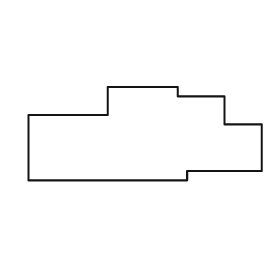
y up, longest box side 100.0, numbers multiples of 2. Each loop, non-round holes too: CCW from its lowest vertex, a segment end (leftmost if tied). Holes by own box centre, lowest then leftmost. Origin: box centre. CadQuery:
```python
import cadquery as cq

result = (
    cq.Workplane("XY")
    .moveTo(-50.0, -20.0)
    .lineTo(18.0, -20.0)
    .lineTo(18.0, -16.0)
    .lineTo(50.0, -16.0)
    .lineTo(50.0, 4.0)
    .lineTo(34.0, 4.0)
    .lineTo(34.0, 16.0)
    .lineTo(14.0, 16.0)
    .lineTo(14.0, 20.0)
    .lineTo(-16.0, 20.0)
    .lineTo(-16.0, 8.0)
    .lineTo(-50.0, 8.0)
    .close()
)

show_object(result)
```